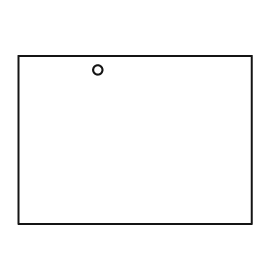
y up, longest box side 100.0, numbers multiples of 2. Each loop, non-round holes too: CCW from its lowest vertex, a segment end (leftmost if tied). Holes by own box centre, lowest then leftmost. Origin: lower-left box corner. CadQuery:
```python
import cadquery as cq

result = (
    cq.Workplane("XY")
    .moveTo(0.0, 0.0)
    .lineTo(100.0, 0.0)
    .lineTo(100.0, 72.0)
    .lineTo(0.0, 72.0)
    .close()
    .moveTo(34.0, 66.0)
    .circle(2.0)
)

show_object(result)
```